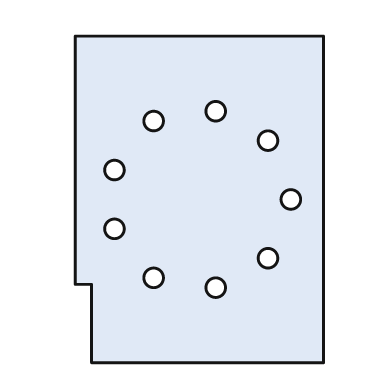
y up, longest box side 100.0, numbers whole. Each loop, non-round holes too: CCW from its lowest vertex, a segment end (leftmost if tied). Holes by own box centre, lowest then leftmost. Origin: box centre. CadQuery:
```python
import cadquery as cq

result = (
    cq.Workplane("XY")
    .moveTo(-33.0, -50.0)
    .lineTo(38.0, -50.0)
    .lineTo(38.0, 50.0)
    .lineTo(-38.0, 50.0)
    .lineTo(-38.0, -26.0)
    .lineTo(-33.0, -26.0)
    .close()
    .moveTo(5.0, -27.0)
    .circle(3.0)
    .moveTo(-14.0, -24.0)
    .circle(3.0)
    .moveTo(21.0, -18.0)
    .circle(3.0)
    .moveTo(-26.0, -9.0)
    .circle(3.0)
    .moveTo(28.0, 0.0)
    .circle(3.0)
    .moveTo(-26.0, 9.0)
    .circle(3.0)
    .moveTo(21.0, 18.0)
    .circle(3.0)
    .moveTo(-14.0, 24.0)
    .circle(3.0)
    .moveTo(5.0, 27.0)
    .circle(3.0)
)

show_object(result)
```